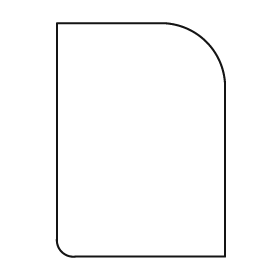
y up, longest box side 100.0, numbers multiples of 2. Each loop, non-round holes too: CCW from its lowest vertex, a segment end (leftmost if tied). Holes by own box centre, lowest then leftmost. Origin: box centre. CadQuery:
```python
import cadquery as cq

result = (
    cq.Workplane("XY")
    .moveTo(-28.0, -50.0)
    .lineTo(36.0, -50.0)
    .lineTo(36.0, 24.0)
    .threePointArc((28.0, 42.0), (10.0, 50.0))
    .lineTo(-36.0, 50.0)
    .lineTo(-36.0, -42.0)
    .threePointArc((-34.0, -48.0), (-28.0, -50.0))
    .close()
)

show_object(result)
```